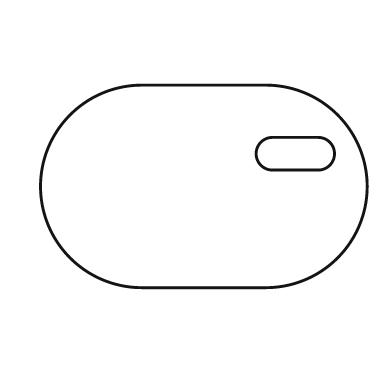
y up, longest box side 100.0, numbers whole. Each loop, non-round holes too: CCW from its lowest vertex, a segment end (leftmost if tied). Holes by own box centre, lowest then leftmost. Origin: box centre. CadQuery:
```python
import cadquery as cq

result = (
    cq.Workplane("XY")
    .moveTo(-19.0, -31.0)
    .lineTo(19.0, -31.0)
    .threePointArc((50.0, 0.0), (19.0, 31.0))
    .lineTo(-19.0, 31.0)
    .threePointArc((-50.0, 0.0), (-19.0, -31.0))
    .close()
    .moveTo(21.0, 5.0)
    .lineTo(35.0, 5.0)
    .threePointArc((40.0, 10.0), (35.0, 15.0))
    .lineTo(21.0, 15.0)
    .threePointArc((16.0, 10.0), (21.0, 5.0))
    .close()
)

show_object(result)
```